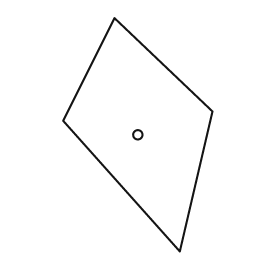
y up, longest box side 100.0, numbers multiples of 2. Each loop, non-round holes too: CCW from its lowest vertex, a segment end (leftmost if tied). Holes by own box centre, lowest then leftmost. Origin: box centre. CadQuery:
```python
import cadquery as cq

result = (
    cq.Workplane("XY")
    .moveTo(18.0, -50.0)
    .lineTo(32.0, 10.0)
    .lineTo(-10.0, 50.0)
    .lineTo(-32.0, 6.0)
    .close()
    .moveTo(0.0, 0.0)
    .circle(2.0)
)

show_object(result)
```